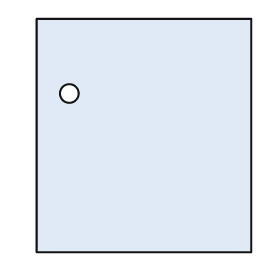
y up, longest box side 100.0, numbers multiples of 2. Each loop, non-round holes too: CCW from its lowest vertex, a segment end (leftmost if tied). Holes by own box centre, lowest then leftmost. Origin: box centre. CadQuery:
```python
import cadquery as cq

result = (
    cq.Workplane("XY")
    .moveTo(-46.0, -50.0)
    .lineTo(46.0, -50.0)
    .lineTo(46.0, 50.0)
    .lineTo(-46.0, 50.0)
    .close()
    .moveTo(-32.0, 18.0)
    .circle(4.0)
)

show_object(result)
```